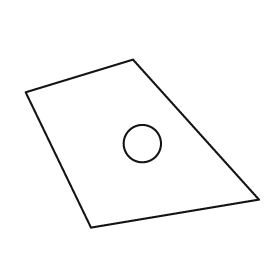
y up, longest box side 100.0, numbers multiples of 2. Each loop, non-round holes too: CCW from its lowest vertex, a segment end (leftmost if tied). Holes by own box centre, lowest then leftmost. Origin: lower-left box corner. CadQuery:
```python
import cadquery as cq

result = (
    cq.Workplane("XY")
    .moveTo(28.0, 0.0)
    .lineTo(100.0, 12.0)
    .lineTo(46.0, 72.0)
    .lineTo(0.0, 58.0)
    .close()
    .moveTo(50.0, 36.0)
    .circle(8.0)
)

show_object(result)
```